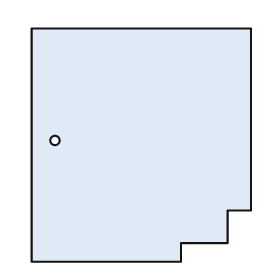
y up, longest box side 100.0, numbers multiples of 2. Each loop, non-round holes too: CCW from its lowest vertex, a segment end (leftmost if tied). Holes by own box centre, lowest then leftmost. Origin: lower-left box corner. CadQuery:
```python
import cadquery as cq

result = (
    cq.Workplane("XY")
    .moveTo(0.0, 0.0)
    .lineTo(64.0, 0.0)
    .lineTo(64.0, 8.0)
    .lineTo(84.0, 8.0)
    .lineTo(84.0, 22.0)
    .lineTo(94.0, 22.0)
    .lineTo(94.0, 100.0)
    .lineTo(0.0, 100.0)
    .close()
    .moveTo(10.0, 52.0)
    .circle(2.0)
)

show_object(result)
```